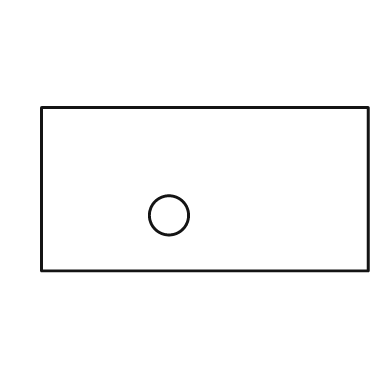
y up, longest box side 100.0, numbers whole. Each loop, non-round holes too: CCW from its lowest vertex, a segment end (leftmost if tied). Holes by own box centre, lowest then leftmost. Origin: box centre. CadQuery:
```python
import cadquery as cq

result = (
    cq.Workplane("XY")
    .moveTo(-50.0, -25.0)
    .lineTo(50.0, -25.0)
    .lineTo(50.0, 25.0)
    .lineTo(-50.0, 25.0)
    .close()
    .moveTo(-11.0, -8.0)
    .circle(6.0)
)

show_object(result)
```